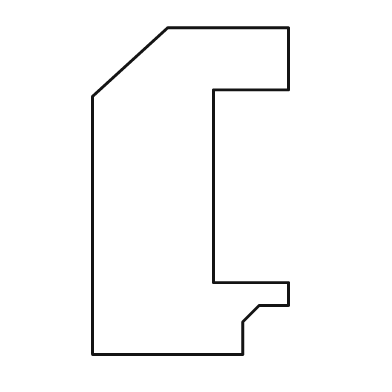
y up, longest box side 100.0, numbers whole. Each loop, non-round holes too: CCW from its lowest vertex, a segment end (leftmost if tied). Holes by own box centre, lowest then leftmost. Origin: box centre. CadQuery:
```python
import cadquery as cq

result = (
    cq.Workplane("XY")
    .moveTo(-30.0, -50.0)
    .lineTo(16.0, -50.0)
    .lineTo(16.0, -40.0)
    .lineTo(21.0, -35.0)
    .lineTo(30.0, -35.0)
    .lineTo(30.0, -28.0)
    .lineTo(7.0, -28.0)
    .lineTo(7.0, 31.0)
    .lineTo(30.0, 31.0)
    .lineTo(30.0, 50.0)
    .lineTo(-7.0, 50.0)
    .lineTo(-30.0, 29.0)
    .close()
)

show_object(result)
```